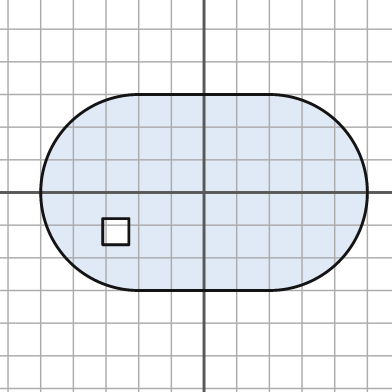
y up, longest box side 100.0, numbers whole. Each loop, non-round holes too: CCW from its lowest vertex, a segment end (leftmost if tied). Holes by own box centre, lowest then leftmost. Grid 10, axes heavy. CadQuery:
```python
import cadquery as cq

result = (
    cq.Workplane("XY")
    .moveTo(-20.0, -30.0)
    .lineTo(20.0, -30.0)
    .threePointArc((50.0, 0.0), (20.0, 30.0))
    .lineTo(-20.0, 30.0)
    .threePointArc((-50.0, 0.0), (-20.0, -30.0))
    .close()
    .moveTo(-31.0, -16.0)
    .lineTo(-23.0, -16.0)
    .lineTo(-23.0, -8.0)
    .lineTo(-31.0, -8.0)
    .close()
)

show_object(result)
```